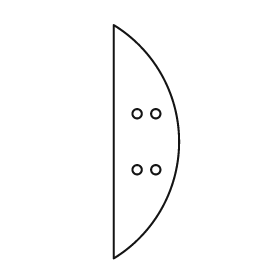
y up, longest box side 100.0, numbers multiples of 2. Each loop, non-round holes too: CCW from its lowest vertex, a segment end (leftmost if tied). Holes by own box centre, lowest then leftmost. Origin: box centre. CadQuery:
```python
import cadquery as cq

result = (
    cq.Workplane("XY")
    .moveTo(-14.0, -50.0)
    .threePointArc((14.0, 0.0), (-14.0, 50.0))
    .close()
    .moveTo(-4.0, -12.0)
    .circle(2.0)
    .moveTo(4.0, -12.0)
    .circle(2.0)
    .moveTo(-4.0, 12.0)
    .circle(2.0)
    .moveTo(4.0, 12.0)
    .circle(2.0)
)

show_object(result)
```